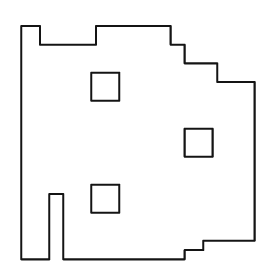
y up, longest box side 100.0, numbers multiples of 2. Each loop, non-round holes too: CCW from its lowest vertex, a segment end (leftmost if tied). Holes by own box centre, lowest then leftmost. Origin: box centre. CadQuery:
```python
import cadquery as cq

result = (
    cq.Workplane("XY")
    .moveTo(-50.0, -50.0)
    .lineTo(-38.0, -50.0)
    .lineTo(-38.0, -22.0)
    .lineTo(-32.0, -22.0)
    .lineTo(-32.0, -50.0)
    .lineTo(20.0, -50.0)
    .lineTo(20.0, -46.0)
    .lineTo(28.0, -46.0)
    .lineTo(28.0, -42.0)
    .lineTo(50.0, -42.0)
    .lineTo(50.0, 26.0)
    .lineTo(34.0, 26.0)
    .lineTo(34.0, 34.0)
    .lineTo(20.0, 34.0)
    .lineTo(20.0, 42.0)
    .lineTo(14.0, 42.0)
    .lineTo(14.0, 50.0)
    .lineTo(-18.0, 50.0)
    .lineTo(-18.0, 42.0)
    .lineTo(-42.0, 42.0)
    .lineTo(-42.0, 50.0)
    .lineTo(-50.0, 50.0)
    .close()
    .moveTo(-20.0, -30.0)
    .lineTo(-8.0, -30.0)
    .lineTo(-8.0, -18.0)
    .lineTo(-20.0, -18.0)
    .close()
    .moveTo(20.0, -6.0)
    .lineTo(32.0, -6.0)
    .lineTo(32.0, 6.0)
    .lineTo(20.0, 6.0)
    .close()
    .moveTo(-20.0, 18.0)
    .lineTo(-8.0, 18.0)
    .lineTo(-8.0, 30.0)
    .lineTo(-20.0, 30.0)
    .close()
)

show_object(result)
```